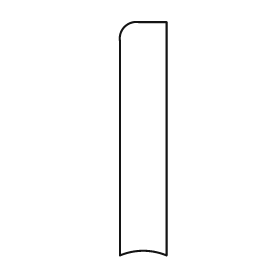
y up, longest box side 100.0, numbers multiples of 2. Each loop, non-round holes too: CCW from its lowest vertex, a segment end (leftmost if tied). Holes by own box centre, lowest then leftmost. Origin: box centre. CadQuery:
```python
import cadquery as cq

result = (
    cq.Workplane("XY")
    .moveTo(-10.0, -50.0)
    .threePointArc((0.0, -48.0), (10.0, -50.0))
    .lineTo(10.0, 50.0)
    .lineTo(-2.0, 50.0)
    .threePointArc((-8.0, 48.0), (-10.0, 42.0))
    .close()
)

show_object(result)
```